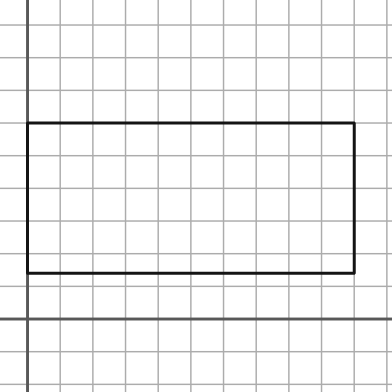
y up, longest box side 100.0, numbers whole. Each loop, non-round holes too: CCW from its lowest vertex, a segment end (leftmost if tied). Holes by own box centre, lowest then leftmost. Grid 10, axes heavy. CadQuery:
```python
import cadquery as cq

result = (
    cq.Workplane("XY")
    .moveTo(0.0, 14.0)
    .lineTo(100.0, 14.0)
    .lineTo(100.0, 60.0)
    .lineTo(0.0, 60.0)
    .close()
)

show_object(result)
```